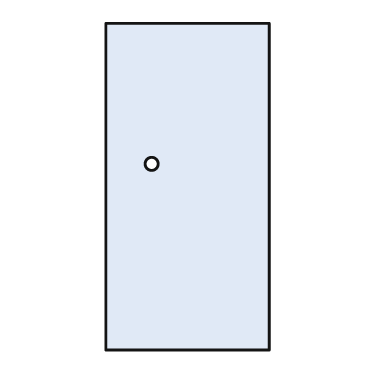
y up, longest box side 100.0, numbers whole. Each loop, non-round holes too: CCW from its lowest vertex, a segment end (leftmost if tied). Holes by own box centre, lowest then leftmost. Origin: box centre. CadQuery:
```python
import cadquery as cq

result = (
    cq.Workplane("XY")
    .moveTo(-25.0, -50.0)
    .lineTo(25.0, -50.0)
    .lineTo(25.0, 50.0)
    .lineTo(-25.0, 50.0)
    .close()
    .moveTo(-11.0, 7.0)
    .circle(2.0)
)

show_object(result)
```